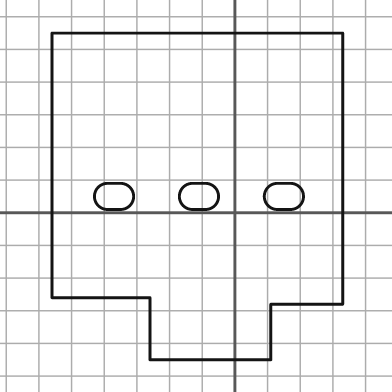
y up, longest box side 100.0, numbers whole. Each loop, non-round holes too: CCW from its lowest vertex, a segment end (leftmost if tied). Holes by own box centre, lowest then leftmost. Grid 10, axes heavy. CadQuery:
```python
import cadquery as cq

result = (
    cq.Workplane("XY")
    .moveTo(-26.0, -45.0)
    .lineTo(11.0, -45.0)
    .lineTo(11.0, -28.0)
    .lineTo(33.0, -28.0)
    .lineTo(33.0, 55.0)
    .lineTo(-56.0, 55.0)
    .lineTo(-56.0, -26.0)
    .lineTo(-26.0, -26.0)
    .close()
    .moveTo(-39.0, 1.0)
    .lineTo(-35.0, 1.0)
    .threePointArc((-31.0, 5.0), (-35.0, 9.0))
    .lineTo(-39.0, 9.0)
    .threePointArc((-43.0, 5.0), (-39.0, 1.0))
    .close()
    .moveTo(-13.0, 1.0)
    .lineTo(-9.0, 1.0)
    .threePointArc((-5.0, 5.0), (-9.0, 9.0))
    .lineTo(-13.0, 9.0)
    .threePointArc((-17.0, 5.0), (-13.0, 1.0))
    .close()
    .moveTo(13.0, 1.0)
    .lineTo(17.0, 1.0)
    .threePointArc((21.0, 5.0), (17.0, 9.0))
    .lineTo(13.0, 9.0)
    .threePointArc((9.0, 5.0), (13.0, 1.0))
    .close()
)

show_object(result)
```